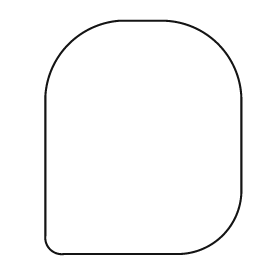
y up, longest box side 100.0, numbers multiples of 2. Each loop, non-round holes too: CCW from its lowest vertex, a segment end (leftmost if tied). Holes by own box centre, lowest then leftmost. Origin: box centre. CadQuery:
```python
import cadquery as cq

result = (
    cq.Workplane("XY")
    .moveTo(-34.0, -50.0)
    .lineTo(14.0, -50.0)
    .threePointArc((34.0, -42.0), (42.0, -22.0))
    .lineTo(42.0, 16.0)
    .threePointArc((32.0, 40.0), (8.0, 50.0))
    .lineTo(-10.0, 50.0)
    .threePointArc((-32.0, 40.0), (-42.0, 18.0))
    .lineTo(-42.0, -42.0)
    .threePointArc((-40.0, -48.0), (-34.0, -50.0))
    .close()
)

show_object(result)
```